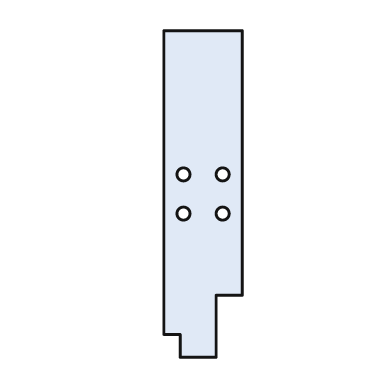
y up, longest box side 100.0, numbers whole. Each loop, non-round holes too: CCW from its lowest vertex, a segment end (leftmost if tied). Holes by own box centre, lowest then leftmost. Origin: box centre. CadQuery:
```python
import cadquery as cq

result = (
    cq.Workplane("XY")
    .moveTo(-7.0, -50.0)
    .lineTo(4.0, -50.0)
    .lineTo(4.0, -31.0)
    .lineTo(12.0, -31.0)
    .lineTo(12.0, 50.0)
    .lineTo(-12.0, 50.0)
    .lineTo(-12.0, -43.0)
    .lineTo(-7.0, -43.0)
    .close()
    .moveTo(-6.0, -6.0)
    .circle(2.0)
    .moveTo(6.0, -6.0)
    .circle(2.0)
    .moveTo(-6.0, 6.0)
    .circle(2.0)
    .moveTo(6.0, 6.0)
    .circle(2.0)
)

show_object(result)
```